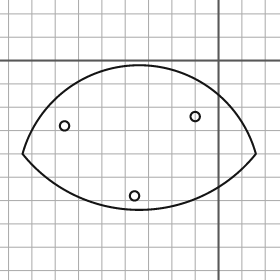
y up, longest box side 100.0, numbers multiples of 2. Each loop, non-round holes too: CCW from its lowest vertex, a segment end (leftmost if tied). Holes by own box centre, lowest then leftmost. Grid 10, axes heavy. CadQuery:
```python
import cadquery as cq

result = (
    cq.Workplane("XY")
    .moveTo(-84.0, -40.0)
    .threePointArc((-34.0, -64.0), (16.0, -40.0))
    .threePointArc((-34.0, -2.0), (-84.0, -40.0))
    .close()
    .moveTo(-36.0, -58.0)
    .circle(2.0)
    .moveTo(-66.0, -28.0)
    .circle(2.0)
    .moveTo(-10.0, -24.0)
    .circle(2.0)
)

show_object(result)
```